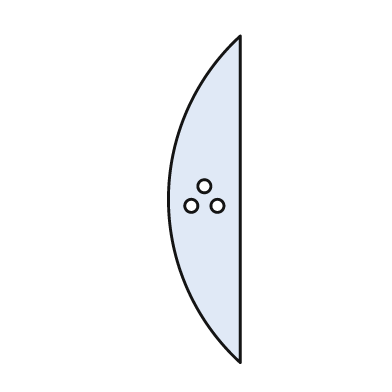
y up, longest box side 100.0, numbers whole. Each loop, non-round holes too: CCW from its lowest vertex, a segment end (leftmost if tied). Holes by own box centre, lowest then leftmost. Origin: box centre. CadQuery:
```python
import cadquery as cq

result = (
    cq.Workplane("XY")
    .moveTo(11.0, -50.0)
    .lineTo(11.0, 50.0)
    .threePointArc((-11.0, 0.0), (11.0, -50.0))
    .close()
    .moveTo(-4.0, -2.0)
    .circle(2.0)
    .moveTo(4.0, -2.0)
    .circle(2.0)
    .moveTo(0.0, 4.0)
    .circle(2.0)
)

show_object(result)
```